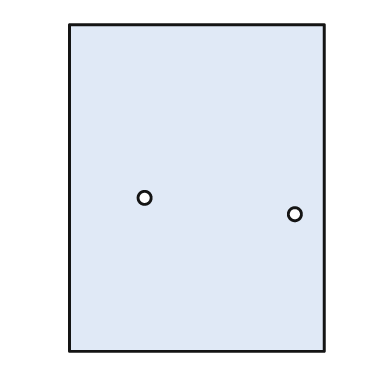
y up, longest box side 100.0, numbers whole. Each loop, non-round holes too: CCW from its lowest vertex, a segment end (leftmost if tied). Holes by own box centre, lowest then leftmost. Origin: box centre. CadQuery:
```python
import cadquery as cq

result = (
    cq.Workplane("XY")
    .moveTo(-39.0, -50.0)
    .lineTo(39.0, -50.0)
    .lineTo(39.0, 50.0)
    .lineTo(-39.0, 50.0)
    .close()
    .moveTo(30.0, -8.0)
    .circle(2.0)
    .moveTo(-16.0, -3.0)
    .circle(2.0)
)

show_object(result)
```